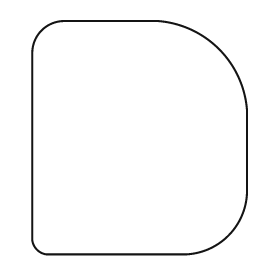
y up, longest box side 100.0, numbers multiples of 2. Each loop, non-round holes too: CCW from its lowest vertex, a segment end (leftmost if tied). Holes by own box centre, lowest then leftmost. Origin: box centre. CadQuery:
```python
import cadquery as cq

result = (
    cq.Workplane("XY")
    .moveTo(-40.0, -50.0)
    .lineTo(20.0, -50.0)
    .threePointArc((38.0, -42.0), (46.0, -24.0))
    .lineTo(46.0, 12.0)
    .threePointArc((34.0, 38.0), (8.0, 50.0))
    .lineTo(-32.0, 50.0)
    .threePointArc((-42.0, 46.0), (-46.0, 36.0))
    .lineTo(-46.0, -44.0)
    .threePointArc((-44.0, -48.0), (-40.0, -50.0))
    .close()
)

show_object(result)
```